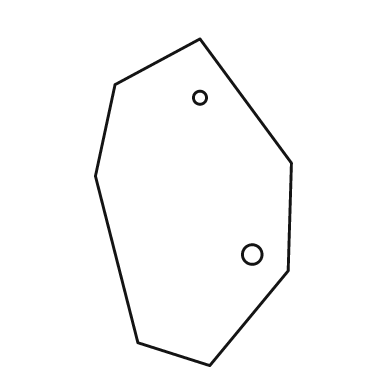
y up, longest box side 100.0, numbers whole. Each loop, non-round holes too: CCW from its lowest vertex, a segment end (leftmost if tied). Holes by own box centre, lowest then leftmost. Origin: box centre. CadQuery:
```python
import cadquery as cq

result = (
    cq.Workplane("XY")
    .moveTo(5.0, -50.0)
    .lineTo(29.0, -21.0)
    .lineTo(30.0, 12.0)
    .lineTo(2.0, 50.0)
    .lineTo(-24.0, 36.0)
    .lineTo(-30.0, 8.0)
    .lineTo(-17.0, -43.0)
    .close()
    .moveTo(18.0, -16.0)
    .circle(3.0)
    .moveTo(2.0, 32.0)
    .circle(2.0)
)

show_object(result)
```